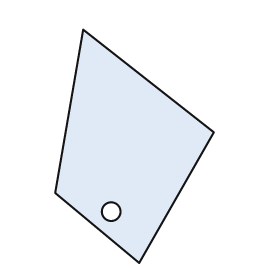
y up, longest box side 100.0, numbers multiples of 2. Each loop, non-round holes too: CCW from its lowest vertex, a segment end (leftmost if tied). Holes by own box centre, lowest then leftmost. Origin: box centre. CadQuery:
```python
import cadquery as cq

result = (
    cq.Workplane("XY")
    .moveTo(2.0, -50.0)
    .lineTo(34.0, 6.0)
    .lineTo(-22.0, 50.0)
    .lineTo(-34.0, -20.0)
    .close()
    .moveTo(-10.0, -28.0)
    .circle(4.0)
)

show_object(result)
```